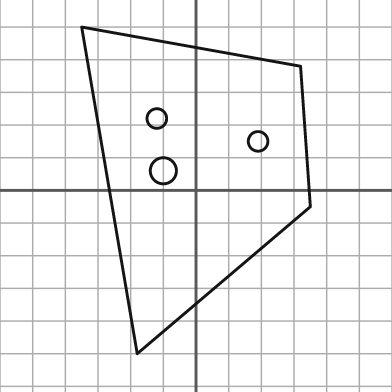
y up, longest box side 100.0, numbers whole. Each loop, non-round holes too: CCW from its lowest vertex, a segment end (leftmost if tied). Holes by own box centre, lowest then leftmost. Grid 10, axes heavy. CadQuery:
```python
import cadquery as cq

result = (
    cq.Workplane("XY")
    .moveTo(-18.0, -50.0)
    .lineTo(35.0, -5.0)
    .lineTo(32.0, 38.0)
    .lineTo(-35.0, 50.0)
    .close()
    .moveTo(-10.0, 6.0)
    .circle(4.0)
    .moveTo(19.0, 15.0)
    .circle(3.0)
    .moveTo(-12.0, 22.0)
    .circle(3.0)
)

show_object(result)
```